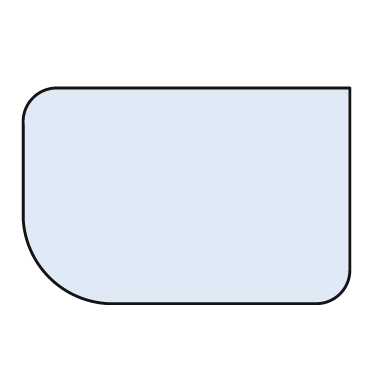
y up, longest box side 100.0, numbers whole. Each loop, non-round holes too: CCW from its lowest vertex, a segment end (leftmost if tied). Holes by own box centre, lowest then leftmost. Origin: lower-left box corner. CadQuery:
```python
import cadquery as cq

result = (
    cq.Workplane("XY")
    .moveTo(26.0, 0.0)
    .lineTo(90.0, 0.0)
    .threePointArc((97.0, 3.0), (100.0, 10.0))
    .lineTo(100.0, 66.0)
    .lineTo(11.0, 66.0)
    .threePointArc((3.0, 63.0), (0.0, 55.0))
    .lineTo(0.0, 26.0)
    .threePointArc((8.0, 8.0), (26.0, 0.0))
    .close()
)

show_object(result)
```